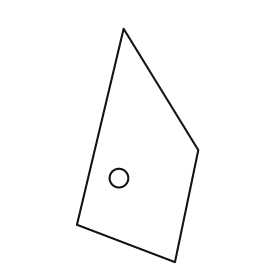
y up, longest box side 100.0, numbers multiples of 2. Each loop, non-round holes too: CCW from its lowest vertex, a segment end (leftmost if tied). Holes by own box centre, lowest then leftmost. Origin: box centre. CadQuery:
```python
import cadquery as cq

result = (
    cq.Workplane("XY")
    .moveTo(16.0, -50.0)
    .lineTo(26.0, -2.0)
    .lineTo(-6.0, 50.0)
    .lineTo(-26.0, -34.0)
    .close()
    .moveTo(-8.0, -14.0)
    .circle(4.0)
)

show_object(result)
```